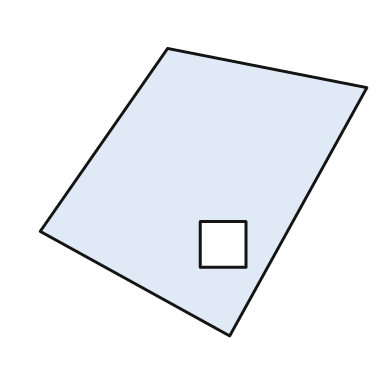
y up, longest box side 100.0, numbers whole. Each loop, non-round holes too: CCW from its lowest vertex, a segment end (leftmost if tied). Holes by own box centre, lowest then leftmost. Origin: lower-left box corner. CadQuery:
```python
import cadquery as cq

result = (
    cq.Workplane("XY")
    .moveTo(58.0, 0.0)
    .lineTo(100.0, 76.0)
    .lineTo(39.0, 88.0)
    .lineTo(0.0, 32.0)
    .close()
    .moveTo(49.0, 21.0)
    .lineTo(63.0, 21.0)
    .lineTo(63.0, 35.0)
    .lineTo(49.0, 35.0)
    .close()
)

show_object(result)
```